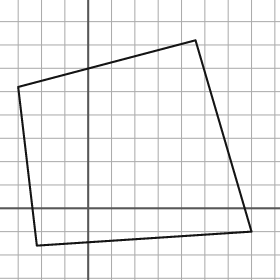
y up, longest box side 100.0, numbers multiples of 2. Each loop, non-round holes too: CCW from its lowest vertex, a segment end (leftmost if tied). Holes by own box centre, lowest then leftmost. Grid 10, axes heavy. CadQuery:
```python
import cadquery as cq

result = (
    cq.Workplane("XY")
    .moveTo(-22.0, -16.0)
    .lineTo(70.0, -10.0)
    .lineTo(46.0, 72.0)
    .lineTo(-30.0, 52.0)
    .close()
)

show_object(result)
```